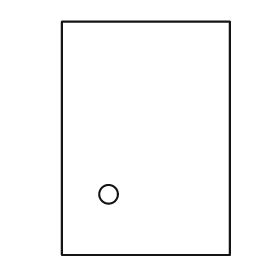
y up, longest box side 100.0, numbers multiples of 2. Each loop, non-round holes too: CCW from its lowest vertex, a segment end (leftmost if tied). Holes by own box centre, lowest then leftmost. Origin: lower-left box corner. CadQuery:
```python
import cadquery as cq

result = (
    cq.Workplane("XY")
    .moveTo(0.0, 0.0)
    .lineTo(72.0, 0.0)
    .lineTo(72.0, 100.0)
    .lineTo(0.0, 100.0)
    .close()
    .moveTo(20.0, 26.0)
    .circle(4.0)
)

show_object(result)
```